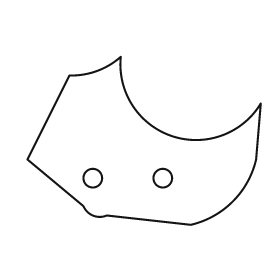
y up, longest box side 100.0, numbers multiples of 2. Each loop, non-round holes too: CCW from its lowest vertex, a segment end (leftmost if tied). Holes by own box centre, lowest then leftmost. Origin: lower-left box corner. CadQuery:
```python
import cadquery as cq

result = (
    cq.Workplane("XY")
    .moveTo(70.0, 0.0)
    .threePointArc((88.0, 10.0), (98.0, 28.0))
    .lineTo(100.0, 52.0)
    .threePointArc((62.0, 38.0), (40.0, 72.0))
    .threePointArc((30.0, 66.0), (18.0, 64.0))
    .lineTo(0.0, 28.0)
    .lineTo(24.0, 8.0)
    .threePointArc((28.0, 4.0), (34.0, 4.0))
    .close()
    .moveTo(28.0, 20.0)
    .circle(4.0)
    .moveTo(58.0, 20.0)
    .circle(4.0)
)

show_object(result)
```